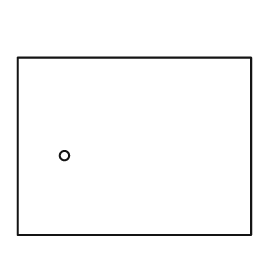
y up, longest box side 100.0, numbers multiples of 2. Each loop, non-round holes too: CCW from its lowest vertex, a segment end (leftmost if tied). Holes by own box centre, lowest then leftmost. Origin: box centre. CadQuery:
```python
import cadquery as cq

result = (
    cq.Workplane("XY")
    .moveTo(-50.0, -38.0)
    .lineTo(50.0, -38.0)
    .lineTo(50.0, 38.0)
    .lineTo(-50.0, 38.0)
    .close()
    .moveTo(-30.0, -4.0)
    .circle(2.0)
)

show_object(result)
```